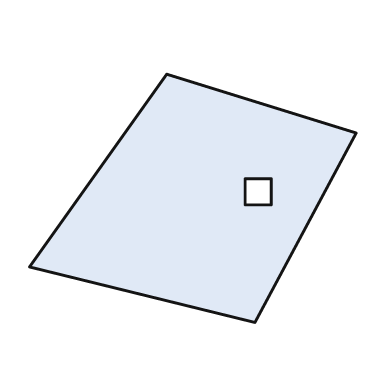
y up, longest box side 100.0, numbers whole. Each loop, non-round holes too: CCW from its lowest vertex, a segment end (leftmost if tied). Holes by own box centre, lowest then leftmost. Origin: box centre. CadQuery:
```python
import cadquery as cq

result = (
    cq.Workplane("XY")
    .moveTo(19.0, -38.0)
    .lineTo(50.0, 20.0)
    .lineTo(-8.0, 38.0)
    .lineTo(-50.0, -21.0)
    .close()
    .moveTo(16.0, -2.0)
    .lineTo(24.0, -2.0)
    .lineTo(24.0, 6.0)
    .lineTo(16.0, 6.0)
    .close()
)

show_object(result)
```